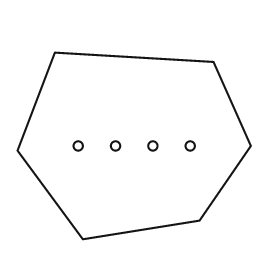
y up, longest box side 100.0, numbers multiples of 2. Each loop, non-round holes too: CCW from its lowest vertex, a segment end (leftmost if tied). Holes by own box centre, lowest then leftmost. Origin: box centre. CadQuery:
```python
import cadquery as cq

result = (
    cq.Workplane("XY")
    .moveTo(-22.0, -40.0)
    .lineTo(28.0, -32.0)
    .lineTo(50.0, 0.0)
    .lineTo(34.0, 36.0)
    .lineTo(-34.0, 40.0)
    .lineTo(-50.0, -2.0)
    .close()
    .moveTo(-24.0, 0.0)
    .circle(2.0)
    .moveTo(-8.0, 0.0)
    .circle(2.0)
    .moveTo(8.0, 0.0)
    .circle(2.0)
    .moveTo(24.0, 0.0)
    .circle(2.0)
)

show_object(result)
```